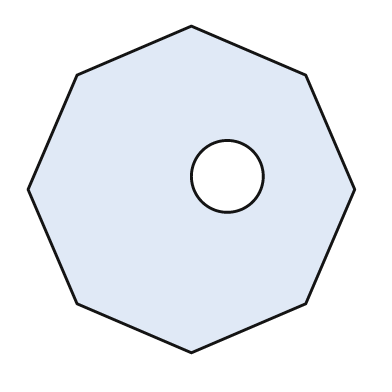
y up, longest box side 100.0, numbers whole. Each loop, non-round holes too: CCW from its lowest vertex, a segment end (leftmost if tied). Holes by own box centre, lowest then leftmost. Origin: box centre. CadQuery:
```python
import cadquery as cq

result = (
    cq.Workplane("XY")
    .moveTo(0.0, -50.0)
    .lineTo(35.0, -35.0)
    .lineTo(50.0, 0.0)
    .lineTo(35.0, 35.0)
    .lineTo(0.0, 50.0)
    .lineTo(-35.0, 35.0)
    .lineTo(-50.0, 0.0)
    .lineTo(-35.0, -35.0)
    .close()
    .moveTo(11.0, 4.0)
    .circle(11.0)
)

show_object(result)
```